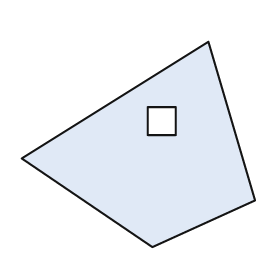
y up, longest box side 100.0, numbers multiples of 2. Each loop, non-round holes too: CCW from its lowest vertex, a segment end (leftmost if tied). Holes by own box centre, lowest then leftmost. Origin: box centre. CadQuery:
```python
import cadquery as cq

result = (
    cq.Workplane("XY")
    .moveTo(6.0, -44.0)
    .lineTo(50.0, -24.0)
    .lineTo(30.0, 44.0)
    .lineTo(-50.0, -6.0)
    .close()
    .moveTo(4.0, 4.0)
    .lineTo(16.0, 4.0)
    .lineTo(16.0, 16.0)
    .lineTo(4.0, 16.0)
    .close()
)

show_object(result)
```